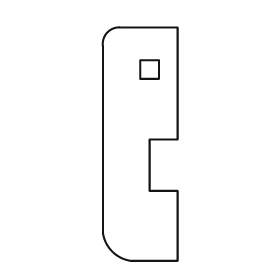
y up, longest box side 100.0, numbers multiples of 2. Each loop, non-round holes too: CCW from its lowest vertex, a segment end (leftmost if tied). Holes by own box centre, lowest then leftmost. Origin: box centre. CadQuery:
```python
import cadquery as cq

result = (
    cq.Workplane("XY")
    .moveTo(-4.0, -50.0)
    .lineTo(16.0, -50.0)
    .lineTo(16.0, -20.0)
    .lineTo(4.0, -20.0)
    .lineTo(4.0, 2.0)
    .lineTo(16.0, 2.0)
    .lineTo(16.0, 50.0)
    .lineTo(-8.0, 50.0)
    .threePointArc((-14.0, 48.0), (-16.0, 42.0))
    .lineTo(-16.0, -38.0)
    .threePointArc((-12.0, -46.0), (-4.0, -50.0))
    .close()
    .moveTo(0.0, 28.0)
    .lineTo(8.0, 28.0)
    .lineTo(8.0, 36.0)
    .lineTo(0.0, 36.0)
    .close()
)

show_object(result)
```